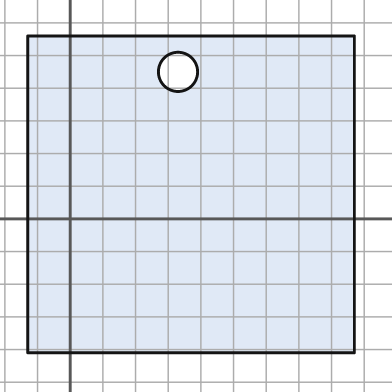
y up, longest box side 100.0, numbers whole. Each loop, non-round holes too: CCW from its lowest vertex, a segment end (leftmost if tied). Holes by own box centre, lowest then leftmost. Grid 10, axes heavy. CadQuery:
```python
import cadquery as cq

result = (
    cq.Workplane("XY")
    .moveTo(-13.0, -41.0)
    .lineTo(87.0, -41.0)
    .lineTo(87.0, 56.0)
    .lineTo(-13.0, 56.0)
    .close()
    .moveTo(33.0, 45.0)
    .circle(6.0)
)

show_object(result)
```